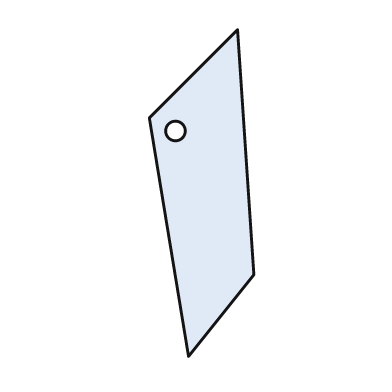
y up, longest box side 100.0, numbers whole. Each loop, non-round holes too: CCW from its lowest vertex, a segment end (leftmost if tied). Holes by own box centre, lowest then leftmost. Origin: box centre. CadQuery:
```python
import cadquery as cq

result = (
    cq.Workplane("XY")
    .moveTo(-4.0, -50.0)
    .lineTo(16.0, -25.0)
    .lineTo(11.0, 50.0)
    .lineTo(-16.0, 23.0)
    .close()
    .moveTo(-8.0, 19.0)
    .circle(3.0)
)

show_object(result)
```